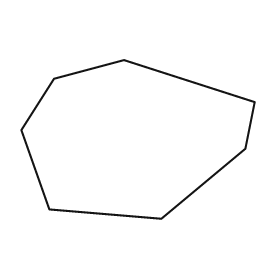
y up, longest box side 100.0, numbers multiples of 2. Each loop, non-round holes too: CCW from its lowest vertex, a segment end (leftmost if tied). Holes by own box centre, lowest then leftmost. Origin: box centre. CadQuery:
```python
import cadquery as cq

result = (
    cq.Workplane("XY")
    .moveTo(10.0, -34.0)
    .lineTo(46.0, -4.0)
    .lineTo(50.0, 16.0)
    .lineTo(-6.0, 34.0)
    .lineTo(-36.0, 26.0)
    .lineTo(-50.0, 4.0)
    .lineTo(-38.0, -30.0)
    .close()
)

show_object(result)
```